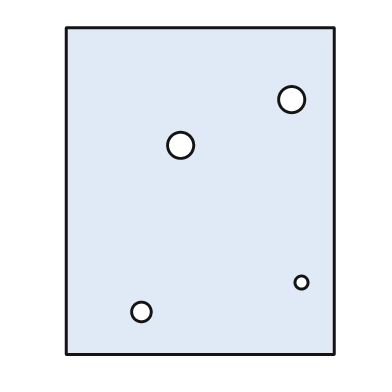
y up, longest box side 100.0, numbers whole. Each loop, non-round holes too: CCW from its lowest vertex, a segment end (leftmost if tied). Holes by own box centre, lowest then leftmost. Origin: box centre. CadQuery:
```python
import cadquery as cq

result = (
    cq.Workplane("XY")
    .moveTo(-41.0, -50.0)
    .lineTo(41.0, -50.0)
    .lineTo(41.0, 50.0)
    .lineTo(-41.0, 50.0)
    .close()
    .moveTo(-18.0, -37.0)
    .circle(3.0)
    .moveTo(31.0, -28.0)
    .circle(2.0)
    .moveTo(-6.0, 14.0)
    .circle(4.0)
    .moveTo(28.0, 28.0)
    .circle(4.0)
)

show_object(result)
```